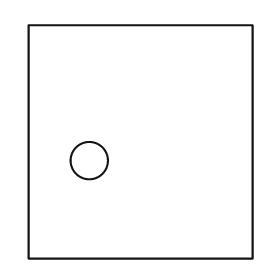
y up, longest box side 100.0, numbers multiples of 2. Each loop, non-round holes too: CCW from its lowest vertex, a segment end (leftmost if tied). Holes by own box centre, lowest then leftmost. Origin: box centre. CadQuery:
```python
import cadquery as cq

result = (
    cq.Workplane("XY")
    .moveTo(-48.0, -50.0)
    .lineTo(48.0, -50.0)
    .lineTo(48.0, 50.0)
    .lineTo(-48.0, 50.0)
    .close()
    .moveTo(-22.0, -8.0)
    .circle(8.0)
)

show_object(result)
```